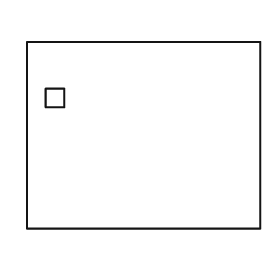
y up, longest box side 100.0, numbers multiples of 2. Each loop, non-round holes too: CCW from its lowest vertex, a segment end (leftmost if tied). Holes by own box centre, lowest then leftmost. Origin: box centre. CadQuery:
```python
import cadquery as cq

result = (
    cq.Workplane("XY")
    .moveTo(-50.0, -40.0)
    .lineTo(50.0, -40.0)
    .lineTo(50.0, 40.0)
    .lineTo(-50.0, 40.0)
    .close()
    .moveTo(-42.0, 12.0)
    .lineTo(-34.0, 12.0)
    .lineTo(-34.0, 20.0)
    .lineTo(-42.0, 20.0)
    .close()
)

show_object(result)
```